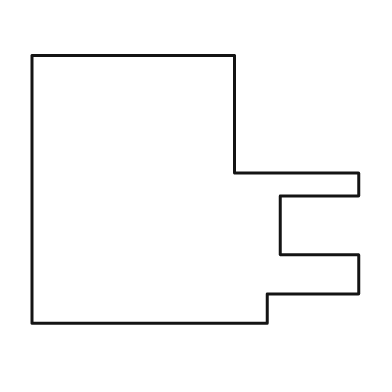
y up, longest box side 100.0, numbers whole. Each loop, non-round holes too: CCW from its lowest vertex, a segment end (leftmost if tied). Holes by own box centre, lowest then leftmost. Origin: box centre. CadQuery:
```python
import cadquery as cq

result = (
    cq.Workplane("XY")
    .moveTo(-50.0, -41.0)
    .lineTo(22.0, -41.0)
    .lineTo(22.0, -32.0)
    .lineTo(50.0, -32.0)
    .lineTo(50.0, -20.0)
    .lineTo(26.0, -20.0)
    .lineTo(26.0, -2.0)
    .lineTo(50.0, -2.0)
    .lineTo(50.0, 5.0)
    .lineTo(12.0, 5.0)
    .lineTo(12.0, 41.0)
    .lineTo(-50.0, 41.0)
    .close()
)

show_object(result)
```